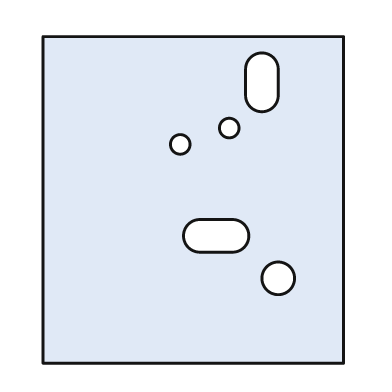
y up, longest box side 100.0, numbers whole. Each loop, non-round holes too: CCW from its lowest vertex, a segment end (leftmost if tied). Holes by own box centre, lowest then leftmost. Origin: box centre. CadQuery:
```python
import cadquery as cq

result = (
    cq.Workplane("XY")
    .moveTo(-46.0, -50.0)
    .lineTo(46.0, -50.0)
    .lineTo(46.0, 50.0)
    .lineTo(-46.0, 50.0)
    .close()
    .moveTo(26.0, -24.0)
    .circle(5.0)
    .moveTo(2.0, -16.0)
    .lineTo(12.0, -16.0)
    .threePointArc((17.0, -11.0), (12.0, -6.0))
    .lineTo(2.0, -6.0)
    .threePointArc((-3.0, -11.0), (2.0, -16.0))
    .close()
    .moveTo(-4.0, 17.0)
    .circle(3.0)
    .moveTo(11.0, 22.0)
    .circle(3.0)
    .moveTo(16.0, 32.0)
    .threePointArc((21.0, 27.0), (26.0, 32.0))
    .lineTo(26.0, 40.0)
    .threePointArc((21.0, 45.0), (16.0, 40.0))
    .close()
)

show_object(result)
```